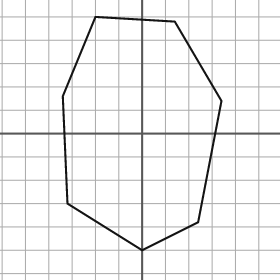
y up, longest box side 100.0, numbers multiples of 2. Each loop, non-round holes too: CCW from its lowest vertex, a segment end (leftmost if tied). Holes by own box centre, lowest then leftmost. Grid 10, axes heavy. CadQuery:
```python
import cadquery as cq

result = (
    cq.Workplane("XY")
    .moveTo(0.0, -50.0)
    .lineTo(24.0, -38.0)
    .lineTo(34.0, 14.0)
    .lineTo(14.0, 48.0)
    .lineTo(-20.0, 50.0)
    .lineTo(-34.0, 16.0)
    .lineTo(-32.0, -30.0)
    .close()
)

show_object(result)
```